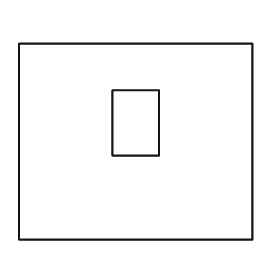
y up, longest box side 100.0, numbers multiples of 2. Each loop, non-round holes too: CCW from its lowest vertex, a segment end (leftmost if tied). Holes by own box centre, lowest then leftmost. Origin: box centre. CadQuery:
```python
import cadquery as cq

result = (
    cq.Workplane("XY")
    .moveTo(-50.0, -42.0)
    .lineTo(50.0, -42.0)
    .lineTo(50.0, 42.0)
    .lineTo(-50.0, 42.0)
    .close()
    .moveTo(-10.0, -6.0)
    .lineTo(10.0, -6.0)
    .lineTo(10.0, 22.0)
    .lineTo(-10.0, 22.0)
    .close()
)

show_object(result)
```